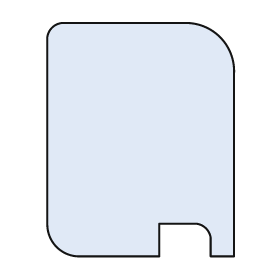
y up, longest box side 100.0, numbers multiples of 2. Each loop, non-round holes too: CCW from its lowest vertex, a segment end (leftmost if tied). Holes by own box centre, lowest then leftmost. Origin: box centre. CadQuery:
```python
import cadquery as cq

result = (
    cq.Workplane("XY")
    .moveTo(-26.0, -50.0)
    .lineTo(8.0, -50.0)
    .lineTo(8.0, -36.0)
    .lineTo(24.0, -36.0)
    .threePointArc((28.0, -38.0), (30.0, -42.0))
    .lineTo(30.0, -50.0)
    .lineTo(40.0, -50.0)
    .lineTo(40.0, 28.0)
    .threePointArc((34.0, 44.0), (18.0, 50.0))
    .lineTo(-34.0, 50.0)
    .threePointArc((-38.0, 48.0), (-40.0, 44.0))
    .lineTo(-40.0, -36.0)
    .threePointArc((-36.0, -46.0), (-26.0, -50.0))
    .close()
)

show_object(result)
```